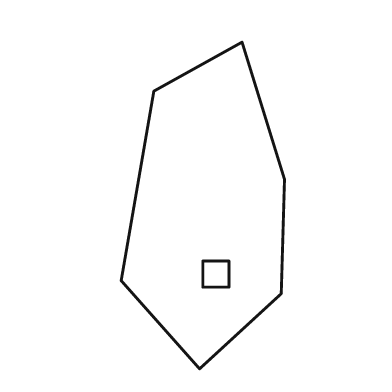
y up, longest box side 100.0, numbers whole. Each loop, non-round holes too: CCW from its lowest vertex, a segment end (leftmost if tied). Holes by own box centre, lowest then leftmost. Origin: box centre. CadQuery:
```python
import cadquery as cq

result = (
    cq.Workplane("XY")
    .moveTo(-1.0, -50.0)
    .lineTo(24.0, -27.0)
    .lineTo(25.0, 8.0)
    .lineTo(12.0, 50.0)
    .lineTo(-15.0, 35.0)
    .lineTo(-25.0, -23.0)
    .close()
    .moveTo(0.0, -25.0)
    .lineTo(8.0, -25.0)
    .lineTo(8.0, -17.0)
    .lineTo(0.0, -17.0)
    .close()
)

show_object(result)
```